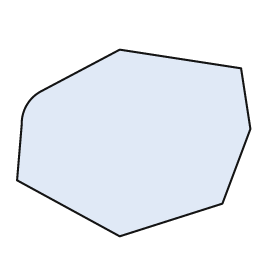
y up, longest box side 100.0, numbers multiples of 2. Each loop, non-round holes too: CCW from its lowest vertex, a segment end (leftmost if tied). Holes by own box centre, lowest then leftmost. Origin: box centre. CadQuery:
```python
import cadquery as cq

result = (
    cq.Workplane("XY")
    .moveTo(-6.0, -40.0)
    .lineTo(38.0, -26.0)
    .lineTo(50.0, 6.0)
    .lineTo(46.0, 32.0)
    .lineTo(-6.0, 40.0)
    .lineTo(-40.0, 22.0)
    .threePointArc((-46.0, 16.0), (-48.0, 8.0))
    .lineTo(-50.0, -16.0)
    .close()
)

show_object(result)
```